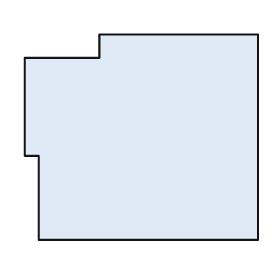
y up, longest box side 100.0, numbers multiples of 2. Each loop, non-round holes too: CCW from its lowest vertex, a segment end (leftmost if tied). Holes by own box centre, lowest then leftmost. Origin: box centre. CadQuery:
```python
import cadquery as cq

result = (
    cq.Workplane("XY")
    .moveTo(-44.0, -44.0)
    .lineTo(50.0, -44.0)
    .lineTo(50.0, 44.0)
    .lineTo(-18.0, 44.0)
    .lineTo(-18.0, 34.0)
    .lineTo(-50.0, 34.0)
    .lineTo(-50.0, -8.0)
    .lineTo(-44.0, -8.0)
    .close()
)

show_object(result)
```